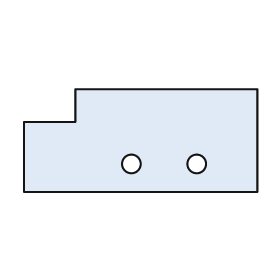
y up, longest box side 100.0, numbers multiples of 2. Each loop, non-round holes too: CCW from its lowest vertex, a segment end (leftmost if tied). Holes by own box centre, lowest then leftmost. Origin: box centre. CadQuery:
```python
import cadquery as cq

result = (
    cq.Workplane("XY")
    .moveTo(-50.0, -22.0)
    .lineTo(50.0, -22.0)
    .lineTo(50.0, 22.0)
    .lineTo(-28.0, 22.0)
    .lineTo(-28.0, 8.0)
    .lineTo(-50.0, 8.0)
    .close()
    .moveTo(-4.0, -10.0)
    .circle(4.0)
    .moveTo(24.0, -10.0)
    .circle(4.0)
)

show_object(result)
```